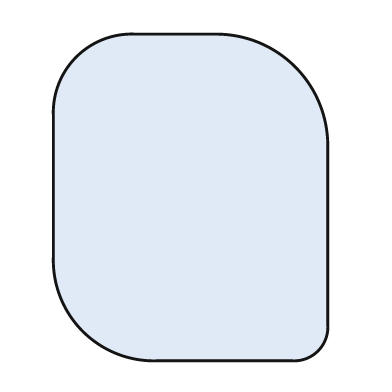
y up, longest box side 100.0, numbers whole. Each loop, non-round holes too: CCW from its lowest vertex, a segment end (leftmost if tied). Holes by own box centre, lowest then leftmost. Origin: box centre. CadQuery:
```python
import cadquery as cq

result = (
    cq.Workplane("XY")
    .moveTo(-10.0, -50.0)
    .lineTo(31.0, -50.0)
    .threePointArc((39.0, -47.0), (42.0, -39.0))
    .lineTo(42.0, 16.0)
    .threePointArc((32.0, 40.0), (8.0, 50.0))
    .lineTo(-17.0, 50.0)
    .threePointArc((-35.0, 43.0), (-42.0, 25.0))
    .lineTo(-42.0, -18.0)
    .threePointArc((-33.0, -41.0), (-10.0, -50.0))
    .close()
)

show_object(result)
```